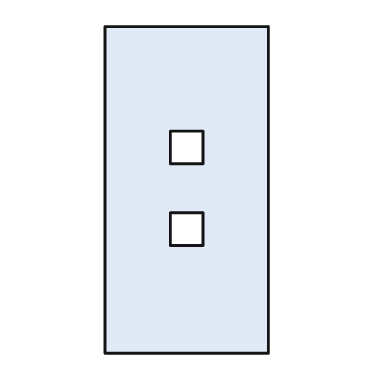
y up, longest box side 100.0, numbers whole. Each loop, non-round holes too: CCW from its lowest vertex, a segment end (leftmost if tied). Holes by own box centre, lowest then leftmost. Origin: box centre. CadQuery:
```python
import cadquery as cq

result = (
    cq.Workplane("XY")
    .moveTo(-25.0, -50.0)
    .lineTo(25.0, -50.0)
    .lineTo(25.0, 50.0)
    .lineTo(-25.0, 50.0)
    .close()
    .moveTo(-5.0, -17.0)
    .lineTo(5.0, -17.0)
    .lineTo(5.0, -7.0)
    .lineTo(-5.0, -7.0)
    .close()
    .moveTo(-5.0, 8.0)
    .lineTo(5.0, 8.0)
    .lineTo(5.0, 18.0)
    .lineTo(-5.0, 18.0)
    .close()
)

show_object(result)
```